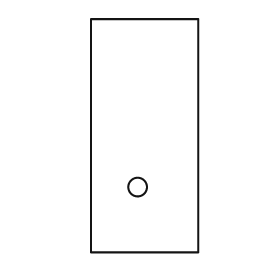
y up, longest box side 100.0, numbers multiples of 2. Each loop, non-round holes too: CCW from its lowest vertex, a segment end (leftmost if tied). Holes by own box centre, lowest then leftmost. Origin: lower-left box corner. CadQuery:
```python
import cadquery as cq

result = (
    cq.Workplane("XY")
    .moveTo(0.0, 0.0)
    .lineTo(46.0, 0.0)
    .lineTo(46.0, 100.0)
    .lineTo(0.0, 100.0)
    .close()
    .moveTo(20.0, 28.0)
    .circle(4.0)
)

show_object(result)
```